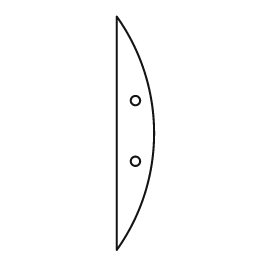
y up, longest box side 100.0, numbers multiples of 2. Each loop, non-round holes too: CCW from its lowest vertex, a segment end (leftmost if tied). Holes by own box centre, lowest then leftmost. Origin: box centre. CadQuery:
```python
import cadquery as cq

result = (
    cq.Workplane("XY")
    .moveTo(-8.0, -50.0)
    .threePointArc((8.0, 0.0), (-8.0, 50.0))
    .close()
    .moveTo(0.0, -12.0)
    .circle(2.0)
    .moveTo(0.0, 14.0)
    .circle(2.0)
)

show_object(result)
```